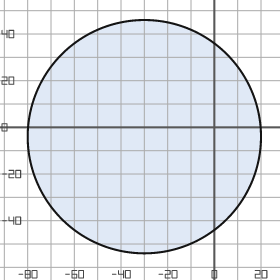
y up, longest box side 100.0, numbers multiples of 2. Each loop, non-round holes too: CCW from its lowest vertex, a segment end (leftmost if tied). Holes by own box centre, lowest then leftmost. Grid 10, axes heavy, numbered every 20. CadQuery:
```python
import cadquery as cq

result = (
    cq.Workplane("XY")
    .moveTo(-30.0, -4.0)
    .circle(50.0)
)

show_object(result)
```